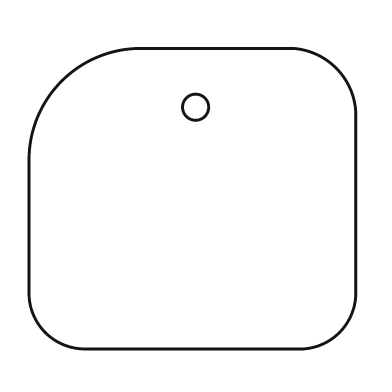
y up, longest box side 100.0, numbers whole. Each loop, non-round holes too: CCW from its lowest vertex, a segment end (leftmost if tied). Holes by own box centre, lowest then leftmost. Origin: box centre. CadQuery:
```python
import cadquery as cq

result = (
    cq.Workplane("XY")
    .moveTo(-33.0, -46.0)
    .lineTo(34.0, -46.0)
    .threePointArc((45.0, -41.0), (50.0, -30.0))
    .lineTo(50.0, 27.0)
    .threePointArc((44.0, 40.0), (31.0, 46.0))
    .lineTo(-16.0, 46.0)
    .threePointArc((-40.0, 36.0), (-50.0, 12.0))
    .lineTo(-50.0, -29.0)
    .threePointArc((-45.0, -41.0), (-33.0, -46.0))
    .close()
    .moveTo(1.0, 28.0)
    .circle(4.0)
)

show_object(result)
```